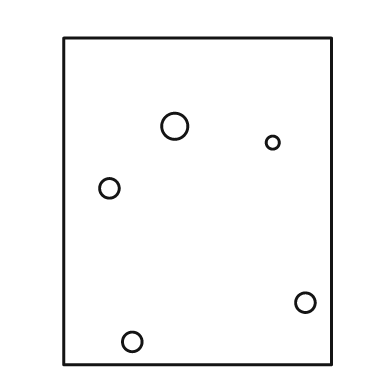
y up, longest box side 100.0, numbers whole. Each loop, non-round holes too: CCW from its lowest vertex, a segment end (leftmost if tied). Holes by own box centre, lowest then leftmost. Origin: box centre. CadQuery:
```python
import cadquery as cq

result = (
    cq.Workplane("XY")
    .moveTo(-41.0, -50.0)
    .lineTo(41.0, -50.0)
    .lineTo(41.0, 50.0)
    .lineTo(-41.0, 50.0)
    .close()
    .moveTo(-20.0, -43.0)
    .circle(3.0)
    .moveTo(33.0, -31.0)
    .circle(3.0)
    .moveTo(-27.0, 4.0)
    .circle(3.0)
    .moveTo(23.0, 18.0)
    .circle(2.0)
    .moveTo(-7.0, 23.0)
    .circle(4.0)
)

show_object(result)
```